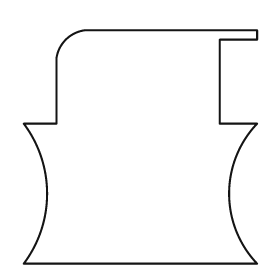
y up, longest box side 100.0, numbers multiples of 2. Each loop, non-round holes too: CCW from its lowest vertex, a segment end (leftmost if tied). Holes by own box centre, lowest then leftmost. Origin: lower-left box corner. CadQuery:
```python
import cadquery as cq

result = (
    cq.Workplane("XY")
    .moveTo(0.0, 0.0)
    .lineTo(100.0, 0.0)
    .threePointArc((88.0, 30.0), (100.0, 60.0))
    .lineTo(84.0, 60.0)
    .lineTo(84.0, 96.0)
    .lineTo(100.0, 96.0)
    .lineTo(100.0, 100.0)
    .lineTo(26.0, 100.0)
    .threePointArc((18.0, 96.0), (14.0, 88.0))
    .lineTo(14.0, 60.0)
    .lineTo(0.0, 60.0)
    .threePointArc((10.0, 30.0), (0.0, 0.0))
    .close()
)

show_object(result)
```